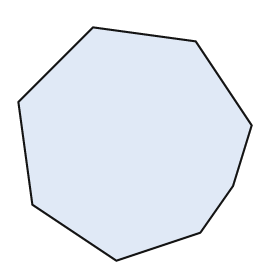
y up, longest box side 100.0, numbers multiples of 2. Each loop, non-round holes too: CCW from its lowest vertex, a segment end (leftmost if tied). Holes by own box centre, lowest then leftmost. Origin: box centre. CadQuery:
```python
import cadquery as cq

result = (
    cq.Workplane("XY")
    .moveTo(-8.0, -50.0)
    .lineTo(28.0, -38.0)
    .lineTo(42.0, -18.0)
    .lineTo(50.0, 8.0)
    .lineTo(26.0, 44.0)
    .lineTo(-18.0, 50.0)
    .lineTo(-50.0, 18.0)
    .lineTo(-44.0, -26.0)
    .close()
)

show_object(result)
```